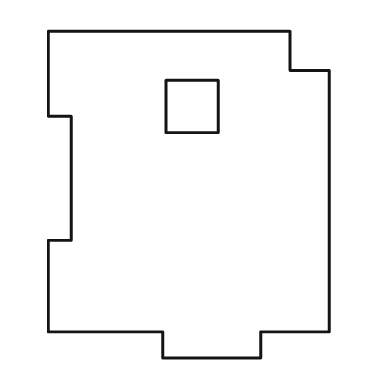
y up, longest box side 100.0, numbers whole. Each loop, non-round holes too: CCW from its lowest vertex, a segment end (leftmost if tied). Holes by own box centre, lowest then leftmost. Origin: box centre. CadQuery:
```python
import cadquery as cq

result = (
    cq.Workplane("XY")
    .moveTo(-8.0, -50.0)
    .lineTo(22.0, -50.0)
    .lineTo(22.0, -42.0)
    .lineTo(43.0, -42.0)
    .lineTo(43.0, 38.0)
    .lineTo(31.0, 38.0)
    .lineTo(31.0, 50.0)
    .lineTo(-43.0, 50.0)
    .lineTo(-43.0, 24.0)
    .lineTo(-36.0, 24.0)
    .lineTo(-36.0, -14.0)
    .lineTo(-43.0, -14.0)
    .lineTo(-43.0, -42.0)
    .lineTo(-8.0, -42.0)
    .close()
    .moveTo(-7.0, 19.0)
    .lineTo(9.0, 19.0)
    .lineTo(9.0, 35.0)
    .lineTo(-7.0, 35.0)
    .close()
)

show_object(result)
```